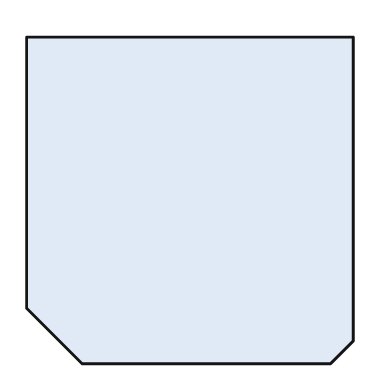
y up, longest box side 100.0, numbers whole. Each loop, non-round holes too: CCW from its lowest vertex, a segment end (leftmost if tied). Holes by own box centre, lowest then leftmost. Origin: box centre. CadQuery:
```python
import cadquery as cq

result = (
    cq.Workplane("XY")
    .moveTo(-33.0, -50.0)
    .lineTo(43.0, -50.0)
    .lineTo(50.0, -43.0)
    .lineTo(50.0, 50.0)
    .lineTo(-50.0, 50.0)
    .lineTo(-50.0, -33.0)
    .close()
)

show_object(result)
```